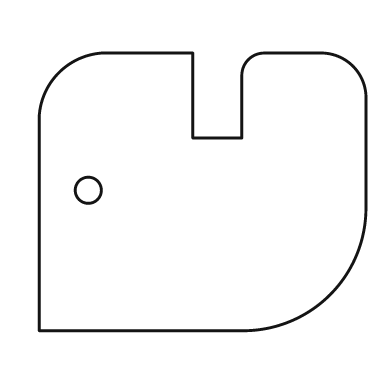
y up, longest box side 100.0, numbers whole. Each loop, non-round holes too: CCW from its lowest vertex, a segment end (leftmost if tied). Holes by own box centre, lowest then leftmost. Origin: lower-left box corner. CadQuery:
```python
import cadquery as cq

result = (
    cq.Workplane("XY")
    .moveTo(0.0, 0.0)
    .lineTo(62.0, 0.0)
    .threePointArc((89.0, 11.0), (100.0, 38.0))
    .lineTo(100.0, 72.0)
    .threePointArc((96.0, 81.0), (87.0, 85.0))
    .lineTo(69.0, 85.0)
    .threePointArc((64.0, 83.0), (62.0, 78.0))
    .lineTo(62.0, 59.0)
    .lineTo(47.0, 59.0)
    .lineTo(47.0, 85.0)
    .lineTo(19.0, 85.0)
    .threePointArc((6.0, 79.0), (0.0, 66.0))
    .close()
    .moveTo(15.0, 43.0)
    .circle(4.0)
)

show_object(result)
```